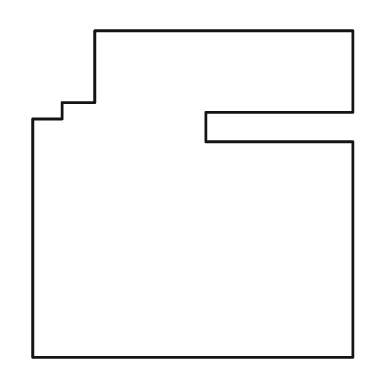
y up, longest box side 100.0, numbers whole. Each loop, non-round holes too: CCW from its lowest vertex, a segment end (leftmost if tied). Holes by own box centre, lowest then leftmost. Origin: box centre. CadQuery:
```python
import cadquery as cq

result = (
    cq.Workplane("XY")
    .moveTo(-49.0, -50.0)
    .lineTo(49.0, -50.0)
    .lineTo(49.0, 16.0)
    .lineTo(4.0, 16.0)
    .lineTo(4.0, 25.0)
    .lineTo(49.0, 25.0)
    .lineTo(49.0, 50.0)
    .lineTo(-30.0, 50.0)
    .lineTo(-30.0, 28.0)
    .lineTo(-40.0, 28.0)
    .lineTo(-40.0, 23.0)
    .lineTo(-49.0, 23.0)
    .close()
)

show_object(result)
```